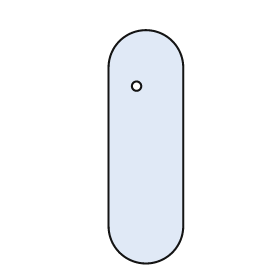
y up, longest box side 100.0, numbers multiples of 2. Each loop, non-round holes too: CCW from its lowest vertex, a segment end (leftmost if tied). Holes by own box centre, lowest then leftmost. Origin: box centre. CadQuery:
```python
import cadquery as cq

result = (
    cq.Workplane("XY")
    .moveTo(-16.0, -34.0)
    .threePointArc((0.0, -50.0), (16.0, -34.0))
    .lineTo(16.0, 34.0)
    .threePointArc((0.0, 50.0), (-16.0, 34.0))
    .close()
    .moveTo(-4.0, 26.0)
    .circle(2.0)
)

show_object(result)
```